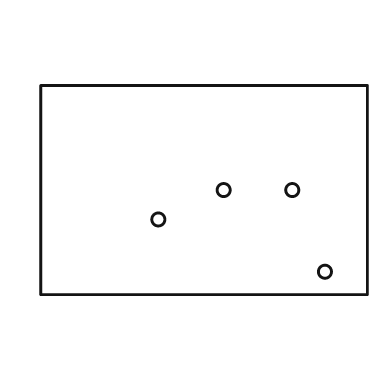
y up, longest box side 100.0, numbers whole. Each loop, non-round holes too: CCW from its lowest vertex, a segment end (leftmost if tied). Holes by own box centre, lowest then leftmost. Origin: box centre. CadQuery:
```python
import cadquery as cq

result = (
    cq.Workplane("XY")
    .moveTo(-50.0, -32.0)
    .lineTo(50.0, -32.0)
    .lineTo(50.0, 32.0)
    .lineTo(-50.0, 32.0)
    .close()
    .moveTo(37.0, -25.0)
    .circle(2.0)
    .moveTo(-14.0, -9.0)
    .circle(2.0)
    .moveTo(6.0, 0.0)
    .circle(2.0)
    .moveTo(27.0, 0.0)
    .circle(2.0)
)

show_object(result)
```